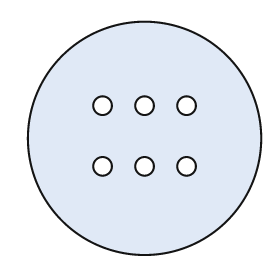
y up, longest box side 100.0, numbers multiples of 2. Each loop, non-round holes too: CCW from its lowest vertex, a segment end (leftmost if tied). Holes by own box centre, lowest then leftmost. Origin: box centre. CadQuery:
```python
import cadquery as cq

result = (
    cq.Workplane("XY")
    .moveTo(0.0, 0.0)
    .circle(50.0)
    .moveTo(-18.0, -12.0)
    .circle(4.0)
    .moveTo(0.0, -12.0)
    .circle(4.0)
    .moveTo(18.0, -12.0)
    .circle(4.0)
    .moveTo(-18.0, 14.0)
    .circle(4.0)
    .moveTo(0.0, 14.0)
    .circle(4.0)
    .moveTo(18.0, 14.0)
    .circle(4.0)
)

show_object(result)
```